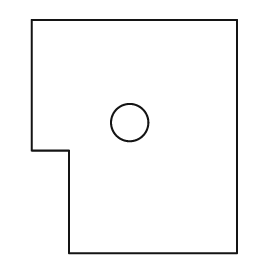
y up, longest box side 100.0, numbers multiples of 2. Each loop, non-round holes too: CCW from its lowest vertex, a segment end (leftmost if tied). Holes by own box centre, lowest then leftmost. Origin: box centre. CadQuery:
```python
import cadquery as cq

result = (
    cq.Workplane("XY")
    .moveTo(-28.0, -50.0)
    .lineTo(44.0, -50.0)
    .lineTo(44.0, 50.0)
    .lineTo(-44.0, 50.0)
    .lineTo(-44.0, -6.0)
    .lineTo(-28.0, -6.0)
    .close()
    .moveTo(-2.0, 6.0)
    .circle(8.0)
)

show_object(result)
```